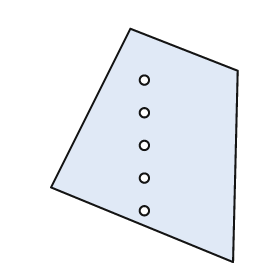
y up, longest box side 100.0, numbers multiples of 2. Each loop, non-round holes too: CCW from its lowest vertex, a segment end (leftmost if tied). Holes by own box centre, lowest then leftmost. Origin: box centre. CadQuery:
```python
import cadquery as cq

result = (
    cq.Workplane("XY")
    .moveTo(38.0, -50.0)
    .lineTo(40.0, 32.0)
    .lineTo(-6.0, 50.0)
    .lineTo(-40.0, -18.0)
    .close()
    .moveTo(0.0, -28.0)
    .circle(2.0)
    .moveTo(0.0, -14.0)
    .circle(2.0)
    .moveTo(0.0, 0.0)
    .circle(2.0)
    .moveTo(0.0, 14.0)
    .circle(2.0)
    .moveTo(0.0, 28.0)
    .circle(2.0)
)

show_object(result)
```